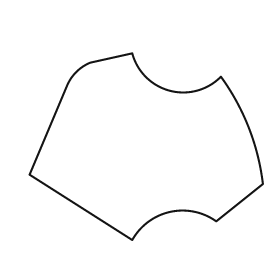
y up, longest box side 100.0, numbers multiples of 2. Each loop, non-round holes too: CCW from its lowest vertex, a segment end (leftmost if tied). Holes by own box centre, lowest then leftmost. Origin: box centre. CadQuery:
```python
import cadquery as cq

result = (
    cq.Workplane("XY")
    .moveTo(-6.0, -40.0)
    .threePointArc((10.0, -28.0), (30.0, -32.0))
    .lineTo(50.0, -16.0)
    .threePointArc((44.0, 8.0), (32.0, 30.0))
    .threePointArc((10.0, 24.0), (-6.0, 40.0))
    .lineTo(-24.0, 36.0)
    .threePointArc((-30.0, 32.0), (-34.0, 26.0))
    .lineTo(-50.0, -12.0)
    .close()
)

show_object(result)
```